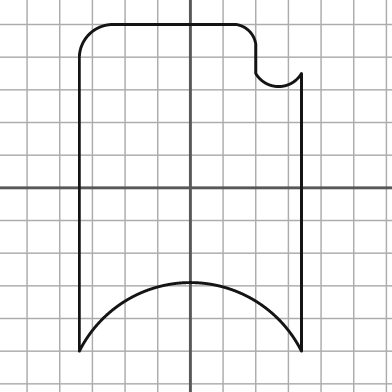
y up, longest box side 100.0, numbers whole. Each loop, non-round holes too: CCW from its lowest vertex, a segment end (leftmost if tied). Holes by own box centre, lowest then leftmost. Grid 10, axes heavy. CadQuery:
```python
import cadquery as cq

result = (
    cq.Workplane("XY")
    .moveTo(-34.0, -50.0)
    .threePointArc((0.0, -29.0), (34.0, -50.0))
    .lineTo(34.0, 35.0)
    .threePointArc((27.0, 31.0), (20.0, 35.0))
    .lineTo(20.0, 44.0)
    .threePointArc((18.0, 48.0), (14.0, 50.0))
    .lineTo(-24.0, 50.0)
    .threePointArc((-31.0, 47.0), (-34.0, 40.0))
    .close()
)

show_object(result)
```